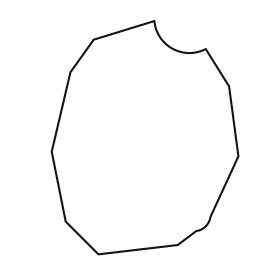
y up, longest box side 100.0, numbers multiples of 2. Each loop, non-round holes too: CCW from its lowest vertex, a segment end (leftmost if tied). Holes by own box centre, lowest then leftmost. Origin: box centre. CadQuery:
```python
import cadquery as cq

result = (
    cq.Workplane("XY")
    .moveTo(-20.0, -50.0)
    .lineTo(14.0, -46.0)
    .lineTo(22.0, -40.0)
    .threePointArc((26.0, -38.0), (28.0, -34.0))
    .lineTo(40.0, -8.0)
    .lineTo(36.0, 22.0)
    .lineTo(26.0, 38.0)
    .threePointArc((12.0, 38.0), (4.0, 50.0))
    .lineTo(-22.0, 42.0)
    .lineTo(-32.0, 28.0)
    .lineTo(-40.0, -6.0)
    .lineTo(-34.0, -36.0)
    .close()
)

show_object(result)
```